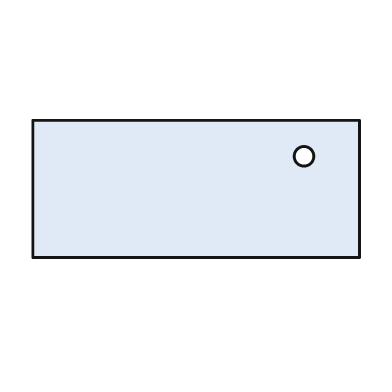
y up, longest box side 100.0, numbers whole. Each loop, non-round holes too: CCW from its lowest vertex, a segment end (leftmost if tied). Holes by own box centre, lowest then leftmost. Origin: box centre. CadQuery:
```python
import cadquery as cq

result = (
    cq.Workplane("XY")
    .moveTo(-50.0, -21.0)
    .lineTo(50.0, -21.0)
    .lineTo(50.0, 21.0)
    .lineTo(-50.0, 21.0)
    .close()
    .moveTo(33.0, 10.0)
    .circle(3.0)
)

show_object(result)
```